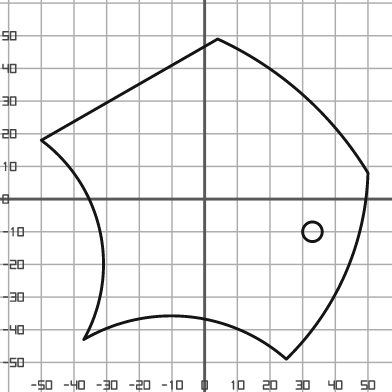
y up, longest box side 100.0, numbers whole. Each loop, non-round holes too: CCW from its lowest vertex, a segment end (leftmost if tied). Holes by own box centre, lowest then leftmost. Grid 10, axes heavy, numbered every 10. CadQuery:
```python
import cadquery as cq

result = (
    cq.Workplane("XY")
    .moveTo(25.0, -49.0)
    .threePointArc((43.0, -23.0), (50.0, 8.0))
    .threePointArc((30.0, 32.0), (4.0, 49.0))
    .lineTo(-50.0, 18.0)
    .threePointArc((-32.0, -10.0), (-37.0, -43.0))
    .threePointArc((-5.0, -36.0), (25.0, -49.0))
    .close()
    .moveTo(33.0, -10.0)
    .circle(3.0)
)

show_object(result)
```